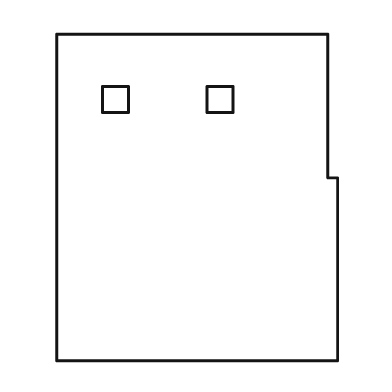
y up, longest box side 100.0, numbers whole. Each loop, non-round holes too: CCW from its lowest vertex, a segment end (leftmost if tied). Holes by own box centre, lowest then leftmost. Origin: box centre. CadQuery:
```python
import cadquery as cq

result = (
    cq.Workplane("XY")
    .moveTo(-43.0, -50.0)
    .lineTo(43.0, -50.0)
    .lineTo(43.0, 6.0)
    .lineTo(40.0, 6.0)
    .lineTo(40.0, 50.0)
    .lineTo(-43.0, 50.0)
    .close()
    .moveTo(-29.0, 26.0)
    .lineTo(-21.0, 26.0)
    .lineTo(-21.0, 34.0)
    .lineTo(-29.0, 34.0)
    .close()
    .moveTo(3.0, 26.0)
    .lineTo(11.0, 26.0)
    .lineTo(11.0, 34.0)
    .lineTo(3.0, 34.0)
    .close()
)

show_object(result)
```